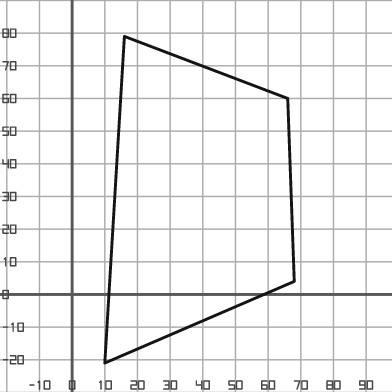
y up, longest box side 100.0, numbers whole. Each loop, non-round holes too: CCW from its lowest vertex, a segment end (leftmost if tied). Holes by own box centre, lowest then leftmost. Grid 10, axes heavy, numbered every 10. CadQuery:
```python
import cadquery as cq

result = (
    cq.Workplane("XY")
    .moveTo(10.0, -21.0)
    .lineTo(68.0, 4.0)
    .lineTo(66.0, 60.0)
    .lineTo(16.0, 79.0)
    .close()
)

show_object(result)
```